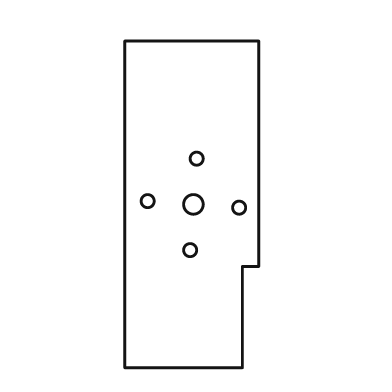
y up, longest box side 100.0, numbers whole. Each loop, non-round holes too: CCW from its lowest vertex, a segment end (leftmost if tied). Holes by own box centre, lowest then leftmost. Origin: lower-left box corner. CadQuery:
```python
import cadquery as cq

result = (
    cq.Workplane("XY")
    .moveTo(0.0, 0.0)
    .lineTo(36.0, 0.0)
    .lineTo(36.0, 31.0)
    .lineTo(41.0, 31.0)
    .lineTo(41.0, 100.0)
    .lineTo(0.0, 100.0)
    .close()
    .moveTo(20.0, 36.0)
    .circle(2.0)
    .moveTo(35.0, 49.0)
    .circle(2.0)
    .moveTo(21.0, 50.0)
    .circle(3.0)
    .moveTo(7.0, 51.0)
    .circle(2.0)
    .moveTo(22.0, 64.0)
    .circle(2.0)
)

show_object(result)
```